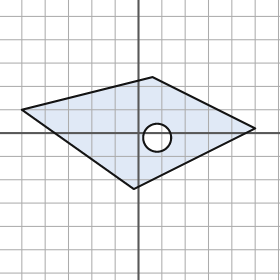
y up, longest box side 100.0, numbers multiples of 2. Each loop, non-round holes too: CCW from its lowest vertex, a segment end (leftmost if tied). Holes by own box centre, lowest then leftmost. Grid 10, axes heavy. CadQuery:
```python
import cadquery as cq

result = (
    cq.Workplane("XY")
    .moveTo(-2.0, -24.0)
    .lineTo(50.0, 2.0)
    .lineTo(6.0, 24.0)
    .lineTo(-50.0, 10.0)
    .close()
    .moveTo(8.0, -2.0)
    .circle(6.0)
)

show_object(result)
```